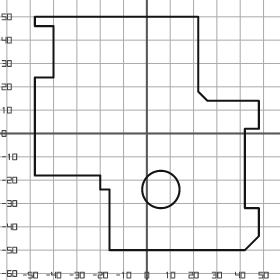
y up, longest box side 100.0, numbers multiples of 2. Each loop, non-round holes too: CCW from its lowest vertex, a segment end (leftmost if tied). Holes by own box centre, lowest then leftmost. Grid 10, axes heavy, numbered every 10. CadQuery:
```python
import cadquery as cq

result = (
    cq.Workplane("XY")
    .moveTo(-16.0, -50.0)
    .lineTo(42.0, -50.0)
    .lineTo(48.0, -44.0)
    .lineTo(48.0, -32.0)
    .lineTo(42.0, -32.0)
    .lineTo(42.0, 2.0)
    .lineTo(48.0, 2.0)
    .lineTo(48.0, 14.0)
    .lineTo(26.0, 14.0)
    .lineTo(22.0, 18.0)
    .lineTo(22.0, 50.0)
    .lineTo(-48.0, 50.0)
    .lineTo(-48.0, 46.0)
    .lineTo(-40.0, 46.0)
    .lineTo(-40.0, 24.0)
    .lineTo(-48.0, 24.0)
    .lineTo(-48.0, -18.0)
    .lineTo(-20.0, -18.0)
    .lineTo(-20.0, -24.0)
    .lineTo(-16.0, -24.0)
    .close()
    .moveTo(6.0, -24.0)
    .circle(8.0)
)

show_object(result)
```